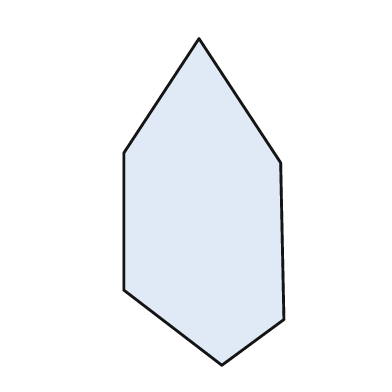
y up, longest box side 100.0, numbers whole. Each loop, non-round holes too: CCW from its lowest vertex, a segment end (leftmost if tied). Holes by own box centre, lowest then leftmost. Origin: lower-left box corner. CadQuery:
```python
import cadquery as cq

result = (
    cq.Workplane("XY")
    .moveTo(30.0, 0.0)
    .lineTo(49.0, 14.0)
    .lineTo(48.0, 62.0)
    .lineTo(23.0, 100.0)
    .lineTo(0.0, 65.0)
    .lineTo(0.0, 23.0)
    .close()
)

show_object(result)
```